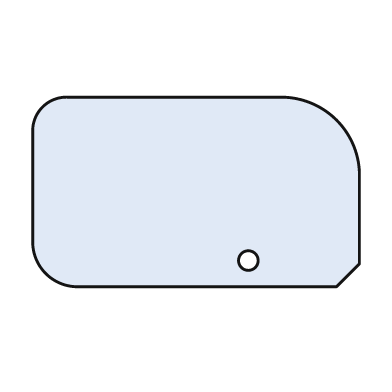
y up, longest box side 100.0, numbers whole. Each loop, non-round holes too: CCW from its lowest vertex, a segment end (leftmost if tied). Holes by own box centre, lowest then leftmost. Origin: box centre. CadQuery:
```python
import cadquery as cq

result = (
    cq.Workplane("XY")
    .moveTo(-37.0, -29.0)
    .lineTo(43.0, -29.0)
    .lineTo(50.0, -22.0)
    .lineTo(50.0, 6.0)
    .threePointArc((43.0, 22.0), (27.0, 29.0))
    .lineTo(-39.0, 29.0)
    .threePointArc((-47.0, 26.0), (-50.0, 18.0))
    .lineTo(-50.0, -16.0)
    .threePointArc((-46.0, -25.0), (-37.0, -29.0))
    .close()
    .moveTo(16.0, -21.0)
    .circle(3.0)
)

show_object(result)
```